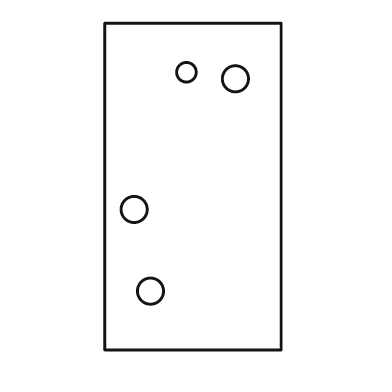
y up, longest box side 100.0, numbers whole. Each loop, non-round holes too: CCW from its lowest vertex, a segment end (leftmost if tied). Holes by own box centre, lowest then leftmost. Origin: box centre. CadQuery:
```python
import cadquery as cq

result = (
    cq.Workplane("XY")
    .moveTo(-27.0, -50.0)
    .lineTo(27.0, -50.0)
    .lineTo(27.0, 50.0)
    .lineTo(-27.0, 50.0)
    .close()
    .moveTo(-13.0, -32.0)
    .circle(4.0)
    .moveTo(-18.0, -7.0)
    .circle(4.0)
    .moveTo(13.0, 33.0)
    .circle(4.0)
    .moveTo(-2.0, 35.0)
    .circle(3.0)
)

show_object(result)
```